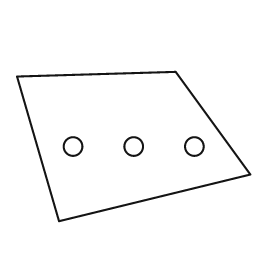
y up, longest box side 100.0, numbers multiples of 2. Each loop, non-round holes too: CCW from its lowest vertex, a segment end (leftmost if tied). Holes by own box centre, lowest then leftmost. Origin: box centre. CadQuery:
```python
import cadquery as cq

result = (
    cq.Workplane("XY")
    .moveTo(-32.0, -32.0)
    .lineTo(50.0, -12.0)
    .lineTo(18.0, 32.0)
    .lineTo(-50.0, 30.0)
    .close()
    .moveTo(-26.0, 0.0)
    .circle(4.0)
    .moveTo(0.0, 0.0)
    .circle(4.0)
    .moveTo(26.0, 0.0)
    .circle(4.0)
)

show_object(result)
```